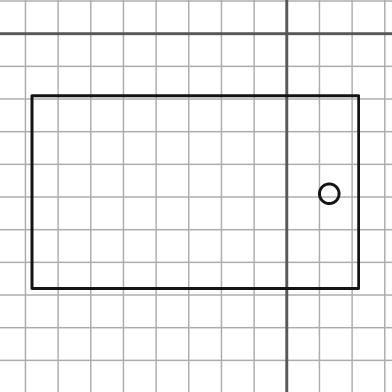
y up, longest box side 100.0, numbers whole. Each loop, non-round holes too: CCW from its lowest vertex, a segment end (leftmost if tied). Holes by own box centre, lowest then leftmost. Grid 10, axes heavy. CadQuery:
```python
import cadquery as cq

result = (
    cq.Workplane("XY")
    .moveTo(-78.0, -78.0)
    .lineTo(22.0, -78.0)
    .lineTo(22.0, -19.0)
    .lineTo(-78.0, -19.0)
    .close()
    .moveTo(13.0, -49.0)
    .circle(3.0)
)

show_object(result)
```